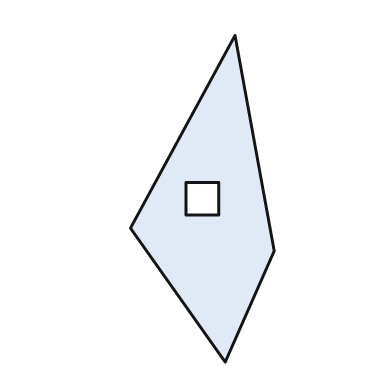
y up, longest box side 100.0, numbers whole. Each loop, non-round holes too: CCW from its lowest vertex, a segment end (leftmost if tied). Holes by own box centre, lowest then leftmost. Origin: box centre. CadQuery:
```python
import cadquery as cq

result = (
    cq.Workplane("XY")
    .moveTo(7.0, -50.0)
    .lineTo(22.0, -16.0)
    .lineTo(10.0, 50.0)
    .lineTo(-22.0, -9.0)
    .close()
    .moveTo(-5.0, -5.0)
    .lineTo(5.0, -5.0)
    .lineTo(5.0, 5.0)
    .lineTo(-5.0, 5.0)
    .close()
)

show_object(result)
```